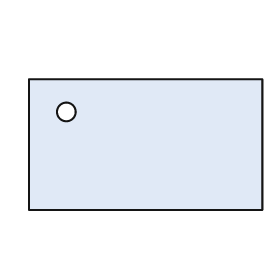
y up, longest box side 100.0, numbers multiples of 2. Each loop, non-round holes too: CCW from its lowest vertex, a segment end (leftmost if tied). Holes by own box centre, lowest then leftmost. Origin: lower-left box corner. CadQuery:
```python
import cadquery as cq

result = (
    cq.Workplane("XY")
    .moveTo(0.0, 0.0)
    .lineTo(100.0, 0.0)
    .lineTo(100.0, 56.0)
    .lineTo(0.0, 56.0)
    .close()
    .moveTo(16.0, 42.0)
    .circle(4.0)
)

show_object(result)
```